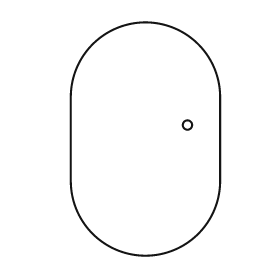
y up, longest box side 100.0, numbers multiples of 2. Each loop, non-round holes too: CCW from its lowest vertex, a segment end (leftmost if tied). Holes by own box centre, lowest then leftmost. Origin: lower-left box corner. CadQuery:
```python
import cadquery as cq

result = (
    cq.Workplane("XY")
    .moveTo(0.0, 32.0)
    .threePointArc((32.0, 0.0), (64.0, 32.0))
    .lineTo(64.0, 68.0)
    .threePointArc((32.0, 100.0), (0.0, 68.0))
    .close()
    .moveTo(50.0, 56.0)
    .circle(2.0)
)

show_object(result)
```